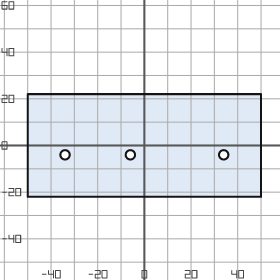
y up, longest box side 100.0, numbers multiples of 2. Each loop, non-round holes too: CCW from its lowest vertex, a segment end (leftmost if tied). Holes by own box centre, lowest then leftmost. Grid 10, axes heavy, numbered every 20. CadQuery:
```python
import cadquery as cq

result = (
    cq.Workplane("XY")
    .moveTo(-50.0, -22.0)
    .lineTo(50.0, -22.0)
    .lineTo(50.0, 22.0)
    .lineTo(-50.0, 22.0)
    .close()
    .moveTo(-34.0, -4.0)
    .circle(2.0)
    .moveTo(-6.0, -4.0)
    .circle(2.0)
    .moveTo(34.0, -4.0)
    .circle(2.0)
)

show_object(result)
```